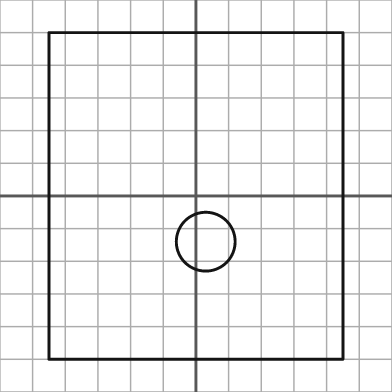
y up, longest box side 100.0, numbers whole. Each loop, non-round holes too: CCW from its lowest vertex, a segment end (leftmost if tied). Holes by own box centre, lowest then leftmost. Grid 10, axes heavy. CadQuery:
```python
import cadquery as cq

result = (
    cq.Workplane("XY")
    .moveTo(-45.0, -50.0)
    .lineTo(45.0, -50.0)
    .lineTo(45.0, 50.0)
    .lineTo(-45.0, 50.0)
    .close()
    .moveTo(3.0, -14.0)
    .circle(9.0)
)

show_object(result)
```